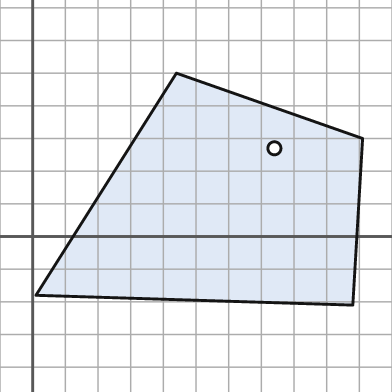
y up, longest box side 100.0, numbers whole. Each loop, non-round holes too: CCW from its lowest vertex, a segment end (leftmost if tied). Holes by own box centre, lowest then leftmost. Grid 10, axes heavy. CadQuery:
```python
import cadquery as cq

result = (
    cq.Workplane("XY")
    .moveTo(98.0, -21.0)
    .lineTo(101.0, 30.0)
    .lineTo(44.0, 50.0)
    .lineTo(1.0, -18.0)
    .close()
    .moveTo(74.0, 27.0)
    .circle(2.0)
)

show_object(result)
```